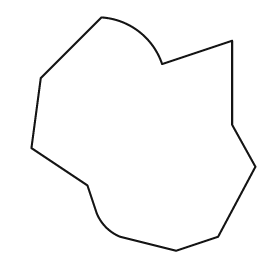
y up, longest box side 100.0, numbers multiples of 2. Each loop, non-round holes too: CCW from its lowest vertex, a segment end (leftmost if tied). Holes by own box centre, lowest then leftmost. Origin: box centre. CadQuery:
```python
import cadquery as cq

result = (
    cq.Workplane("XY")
    .moveTo(14.0, -50.0)
    .lineTo(32.0, -44.0)
    .lineTo(48.0, -14.0)
    .lineTo(38.0, 4.0)
    .lineTo(38.0, 40.0)
    .lineTo(8.0, 30.0)
    .threePointArc((-2.0, 44.0), (-18.0, 50.0))
    .lineTo(-44.0, 24.0)
    .lineTo(-48.0, -6.0)
    .lineTo(-24.0, -22.0)
    .lineTo(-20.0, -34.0)
    .threePointArc((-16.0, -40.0), (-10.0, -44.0))
    .close()
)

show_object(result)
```